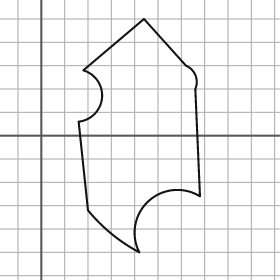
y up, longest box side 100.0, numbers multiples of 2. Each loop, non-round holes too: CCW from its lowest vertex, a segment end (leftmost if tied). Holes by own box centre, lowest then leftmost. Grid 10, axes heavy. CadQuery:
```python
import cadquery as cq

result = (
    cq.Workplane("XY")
    .moveTo(42.0, -50.0)
    .threePointArc((46.0, -28.0), (68.0, -26.0))
    .lineTo(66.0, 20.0)
    .threePointArc((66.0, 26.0), (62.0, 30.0))
    .lineTo(44.0, 50.0)
    .lineTo(18.0, 28.0)
    .threePointArc((26.0, 16.0), (16.0, 6.0))
    .lineTo(20.0, -32.0)
    .threePointArc((30.0, -42.0), (42.0, -50.0))
    .close()
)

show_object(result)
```